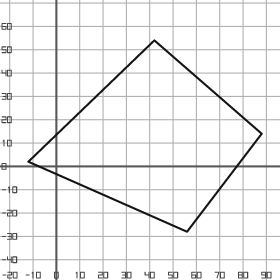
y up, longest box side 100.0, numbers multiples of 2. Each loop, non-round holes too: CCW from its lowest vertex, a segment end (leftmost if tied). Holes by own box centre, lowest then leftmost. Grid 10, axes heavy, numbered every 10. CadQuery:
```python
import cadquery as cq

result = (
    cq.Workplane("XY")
    .moveTo(56.0, -28.0)
    .lineTo(88.0, 14.0)
    .lineTo(42.0, 54.0)
    .lineTo(-12.0, 2.0)
    .close()
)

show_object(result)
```